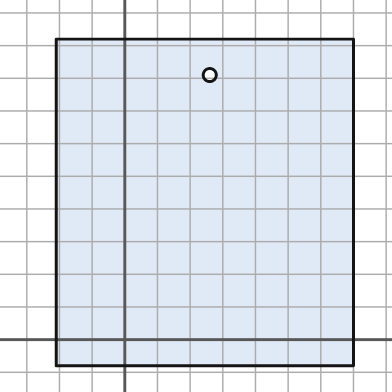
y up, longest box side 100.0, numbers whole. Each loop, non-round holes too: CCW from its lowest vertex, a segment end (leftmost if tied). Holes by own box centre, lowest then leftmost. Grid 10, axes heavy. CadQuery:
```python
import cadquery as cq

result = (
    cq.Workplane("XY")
    .moveTo(-21.0, -8.0)
    .lineTo(70.0, -8.0)
    .lineTo(70.0, 92.0)
    .lineTo(-21.0, 92.0)
    .close()
    .moveTo(26.0, 81.0)
    .circle(2.0)
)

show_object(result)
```